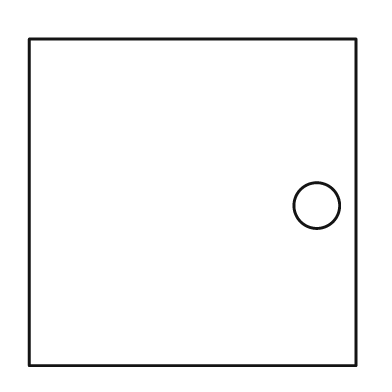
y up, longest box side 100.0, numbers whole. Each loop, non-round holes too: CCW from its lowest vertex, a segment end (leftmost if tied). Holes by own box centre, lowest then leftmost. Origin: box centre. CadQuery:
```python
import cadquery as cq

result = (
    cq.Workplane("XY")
    .moveTo(-50.0, -50.0)
    .lineTo(50.0, -50.0)
    .lineTo(50.0, 50.0)
    .lineTo(-50.0, 50.0)
    .close()
    .moveTo(38.0, -1.0)
    .circle(7.0)
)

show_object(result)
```